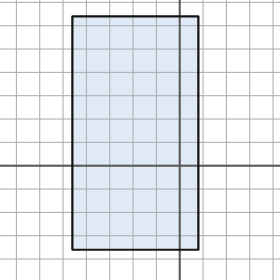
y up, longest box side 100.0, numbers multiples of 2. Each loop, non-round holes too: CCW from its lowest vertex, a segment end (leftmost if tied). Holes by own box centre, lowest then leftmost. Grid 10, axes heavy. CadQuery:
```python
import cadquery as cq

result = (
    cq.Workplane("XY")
    .moveTo(-46.0, -36.0)
    .lineTo(8.0, -36.0)
    .lineTo(8.0, 64.0)
    .lineTo(-46.0, 64.0)
    .close()
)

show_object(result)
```